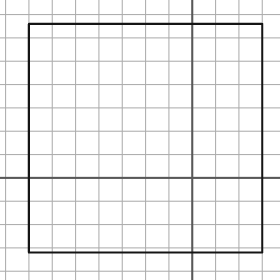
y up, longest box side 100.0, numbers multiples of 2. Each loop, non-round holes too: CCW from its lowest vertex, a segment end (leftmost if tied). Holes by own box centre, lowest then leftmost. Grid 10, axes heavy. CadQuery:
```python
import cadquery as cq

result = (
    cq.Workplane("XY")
    .moveTo(-70.0, -32.0)
    .lineTo(30.0, -32.0)
    .lineTo(30.0, 66.0)
    .lineTo(-70.0, 66.0)
    .close()
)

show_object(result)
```